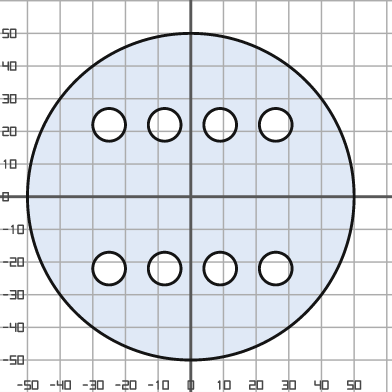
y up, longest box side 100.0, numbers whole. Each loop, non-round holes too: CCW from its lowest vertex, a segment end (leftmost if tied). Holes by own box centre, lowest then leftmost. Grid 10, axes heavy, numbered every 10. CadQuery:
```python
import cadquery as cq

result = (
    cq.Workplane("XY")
    .moveTo(0.0, 0.0)
    .circle(50.0)
    .moveTo(-25.0, -22.0)
    .circle(5.0)
    .moveTo(-8.0, -22.0)
    .circle(5.0)
    .moveTo(9.0, -22.0)
    .circle(5.0)
    .moveTo(26.0, -22.0)
    .circle(5.0)
    .moveTo(-25.0, 22.0)
    .circle(5.0)
    .moveTo(-8.0, 22.0)
    .circle(5.0)
    .moveTo(9.0, 22.0)
    .circle(5.0)
    .moveTo(26.0, 22.0)
    .circle(5.0)
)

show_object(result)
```